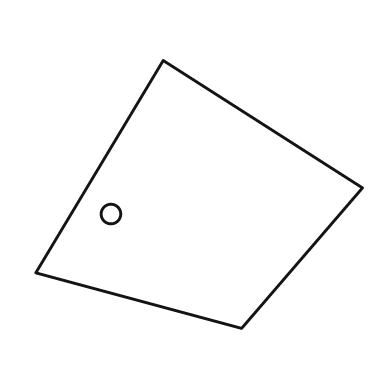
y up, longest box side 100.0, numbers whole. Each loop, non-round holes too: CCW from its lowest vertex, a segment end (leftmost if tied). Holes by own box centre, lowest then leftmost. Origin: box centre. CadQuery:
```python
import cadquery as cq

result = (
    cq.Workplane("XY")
    .moveTo(13.0, -41.0)
    .lineTo(50.0, 2.0)
    .lineTo(-11.0, 41.0)
    .lineTo(-50.0, -24.0)
    .close()
    .moveTo(-27.0, -6.0)
    .circle(3.0)
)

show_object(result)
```